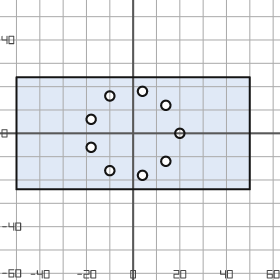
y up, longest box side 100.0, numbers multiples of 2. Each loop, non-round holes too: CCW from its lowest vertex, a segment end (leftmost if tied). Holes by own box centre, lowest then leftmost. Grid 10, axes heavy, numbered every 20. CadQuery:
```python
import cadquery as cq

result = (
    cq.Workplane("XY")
    .moveTo(-50.0, -24.0)
    .lineTo(50.0, -24.0)
    .lineTo(50.0, 24.0)
    .lineTo(-50.0, 24.0)
    .close()
    .moveTo(4.0, -18.0)
    .circle(2.0)
    .moveTo(-10.0, -16.0)
    .circle(2.0)
    .moveTo(14.0, -12.0)
    .circle(2.0)
    .moveTo(-18.0, -6.0)
    .circle(2.0)
    .moveTo(20.0, 0.0)
    .circle(2.0)
    .moveTo(-18.0, 6.0)
    .circle(2.0)
    .moveTo(14.0, 12.0)
    .circle(2.0)
    .moveTo(-10.0, 16.0)
    .circle(2.0)
    .moveTo(4.0, 18.0)
    .circle(2.0)
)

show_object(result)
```